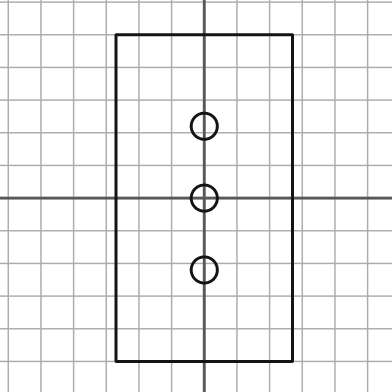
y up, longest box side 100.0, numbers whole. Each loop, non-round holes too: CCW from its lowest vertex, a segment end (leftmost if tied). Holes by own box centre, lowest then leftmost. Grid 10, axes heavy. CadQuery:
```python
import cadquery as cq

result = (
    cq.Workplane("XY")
    .moveTo(-27.0, -50.0)
    .lineTo(27.0, -50.0)
    .lineTo(27.0, 50.0)
    .lineTo(-27.0, 50.0)
    .close()
    .moveTo(0.0, -22.0)
    .circle(4.0)
    .moveTo(0.0, 0.0)
    .circle(4.0)
    .moveTo(0.0, 22.0)
    .circle(4.0)
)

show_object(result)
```